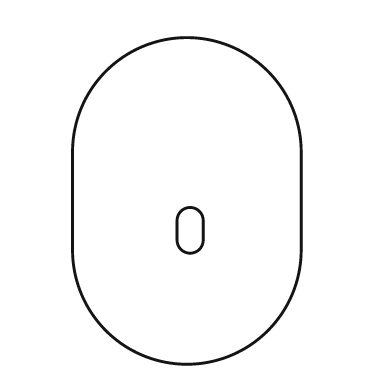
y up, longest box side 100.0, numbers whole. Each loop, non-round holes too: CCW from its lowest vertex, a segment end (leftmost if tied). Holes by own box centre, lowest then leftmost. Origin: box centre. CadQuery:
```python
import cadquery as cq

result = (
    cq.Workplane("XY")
    .moveTo(-35.0, -15.0)
    .threePointArc((0.0, -50.0), (35.0, -15.0))
    .lineTo(35.0, 15.0)
    .threePointArc((0.0, 50.0), (-35.0, 15.0))
    .close()
    .moveTo(-3.0, -12.0)
    .threePointArc((1.0, -16.0), (5.0, -12.0))
    .lineTo(5.0, -6.0)
    .threePointArc((1.0, -2.0), (-3.0, -6.0))
    .close()
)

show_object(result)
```